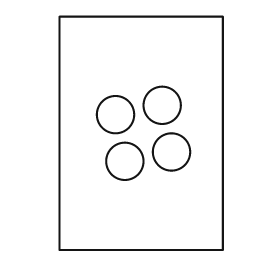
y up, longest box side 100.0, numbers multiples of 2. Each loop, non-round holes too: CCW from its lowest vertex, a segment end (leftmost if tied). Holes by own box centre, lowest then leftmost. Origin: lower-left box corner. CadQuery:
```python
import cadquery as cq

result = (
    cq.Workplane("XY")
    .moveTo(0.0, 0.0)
    .lineTo(70.0, 0.0)
    .lineTo(70.0, 100.0)
    .lineTo(0.0, 100.0)
    .close()
    .moveTo(28.0, 38.0)
    .circle(8.0)
    .moveTo(48.0, 42.0)
    .circle(8.0)
    .moveTo(24.0, 58.0)
    .circle(8.0)
    .moveTo(44.0, 62.0)
    .circle(8.0)
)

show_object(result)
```